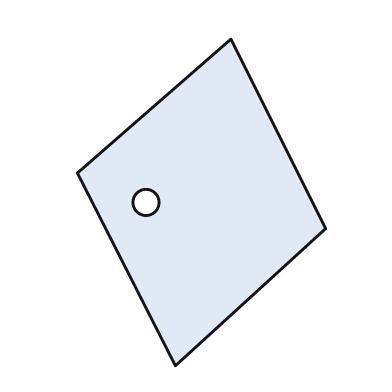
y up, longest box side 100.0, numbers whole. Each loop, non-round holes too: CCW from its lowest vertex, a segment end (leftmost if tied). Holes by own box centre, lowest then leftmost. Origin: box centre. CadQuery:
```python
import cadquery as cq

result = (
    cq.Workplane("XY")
    .moveTo(-8.0, -50.0)
    .lineTo(38.0, -8.0)
    .lineTo(9.0, 50.0)
    .lineTo(-38.0, 9.0)
    .close()
    .moveTo(-17.0, 0.0)
    .circle(4.0)
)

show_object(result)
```